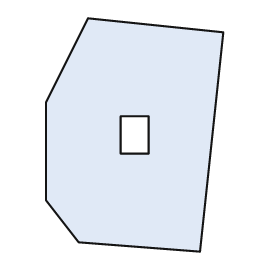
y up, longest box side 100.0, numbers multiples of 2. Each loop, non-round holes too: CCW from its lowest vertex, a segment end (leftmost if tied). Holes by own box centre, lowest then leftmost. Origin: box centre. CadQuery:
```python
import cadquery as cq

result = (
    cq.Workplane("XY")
    .moveTo(28.0, -50.0)
    .lineTo(38.0, 44.0)
    .lineTo(-20.0, 50.0)
    .lineTo(-38.0, 14.0)
    .lineTo(-38.0, -28.0)
    .lineTo(-24.0, -46.0)
    .close()
    .moveTo(-6.0, -8.0)
    .lineTo(6.0, -8.0)
    .lineTo(6.0, 8.0)
    .lineTo(-6.0, 8.0)
    .close()
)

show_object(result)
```